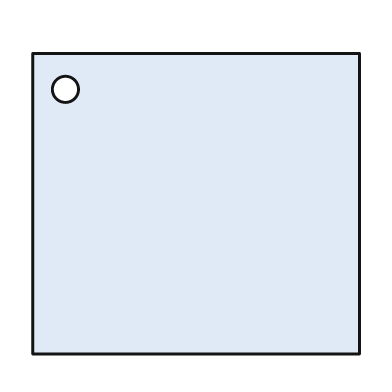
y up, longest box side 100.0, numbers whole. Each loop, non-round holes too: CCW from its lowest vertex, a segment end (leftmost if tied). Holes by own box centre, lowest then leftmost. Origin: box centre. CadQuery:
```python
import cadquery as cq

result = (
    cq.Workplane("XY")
    .moveTo(-50.0, -46.0)
    .lineTo(50.0, -46.0)
    .lineTo(50.0, 46.0)
    .lineTo(-50.0, 46.0)
    .close()
    .moveTo(-40.0, 35.0)
    .circle(4.0)
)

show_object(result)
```